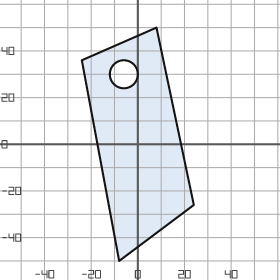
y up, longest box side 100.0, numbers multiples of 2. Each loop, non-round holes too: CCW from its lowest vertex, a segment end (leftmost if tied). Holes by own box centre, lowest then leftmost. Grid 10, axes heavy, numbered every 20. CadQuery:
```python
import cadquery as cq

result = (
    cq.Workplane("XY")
    .moveTo(-8.0, -50.0)
    .lineTo(24.0, -26.0)
    .lineTo(8.0, 50.0)
    .lineTo(-24.0, 36.0)
    .close()
    .moveTo(-6.0, 30.0)
    .circle(6.0)
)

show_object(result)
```